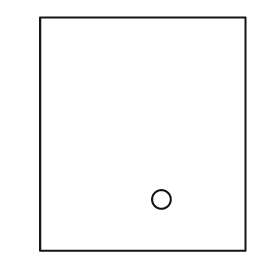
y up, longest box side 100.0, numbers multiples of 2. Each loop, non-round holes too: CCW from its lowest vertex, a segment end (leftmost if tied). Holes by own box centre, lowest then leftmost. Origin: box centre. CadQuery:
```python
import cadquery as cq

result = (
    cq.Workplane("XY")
    .moveTo(-44.0, -50.0)
    .lineTo(44.0, -50.0)
    .lineTo(44.0, 50.0)
    .lineTo(-44.0, 50.0)
    .close()
    .moveTo(8.0, -28.0)
    .circle(4.0)
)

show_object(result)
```